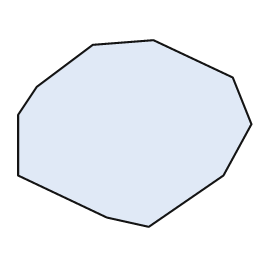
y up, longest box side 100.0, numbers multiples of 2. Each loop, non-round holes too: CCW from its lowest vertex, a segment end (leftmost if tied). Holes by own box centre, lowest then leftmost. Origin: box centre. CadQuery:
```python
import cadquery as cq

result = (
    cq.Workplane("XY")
    .moveTo(6.0, -40.0)
    .lineTo(38.0, -18.0)
    .lineTo(50.0, 4.0)
    .lineTo(42.0, 24.0)
    .lineTo(8.0, 40.0)
    .lineTo(-18.0, 38.0)
    .lineTo(-42.0, 20.0)
    .lineTo(-50.0, 8.0)
    .lineTo(-50.0, -18.0)
    .lineTo(-12.0, -36.0)
    .close()
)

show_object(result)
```